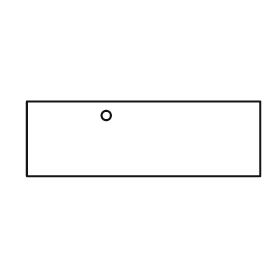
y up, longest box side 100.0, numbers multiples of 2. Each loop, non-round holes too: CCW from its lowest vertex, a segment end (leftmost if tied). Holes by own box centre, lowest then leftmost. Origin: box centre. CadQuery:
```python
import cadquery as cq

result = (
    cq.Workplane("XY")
    .moveTo(-50.0, -16.0)
    .lineTo(50.0, -16.0)
    .lineTo(50.0, 16.0)
    .lineTo(-50.0, 16.0)
    .close()
    .moveTo(-16.0, 10.0)
    .circle(2.0)
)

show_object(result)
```